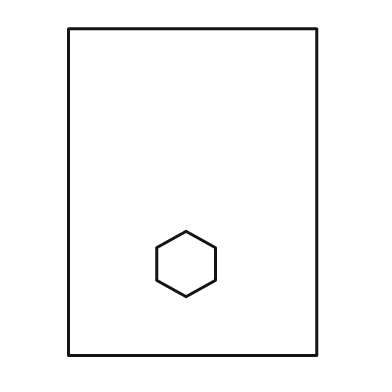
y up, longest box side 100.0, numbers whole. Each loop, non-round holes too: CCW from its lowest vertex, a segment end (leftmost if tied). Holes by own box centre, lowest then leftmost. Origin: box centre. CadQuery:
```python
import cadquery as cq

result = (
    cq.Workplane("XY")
    .moveTo(-38.0, -50.0)
    .lineTo(38.0, -50.0)
    .lineTo(38.0, 50.0)
    .lineTo(-38.0, 50.0)
    .close()
    .moveTo(-2.0, -32.0)
    .lineTo(7.0, -27.0)
    .lineTo(7.0, -17.0)
    .lineTo(-2.0, -12.0)
    .lineTo(-11.0, -17.0)
    .lineTo(-11.0, -27.0)
    .close()
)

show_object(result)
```